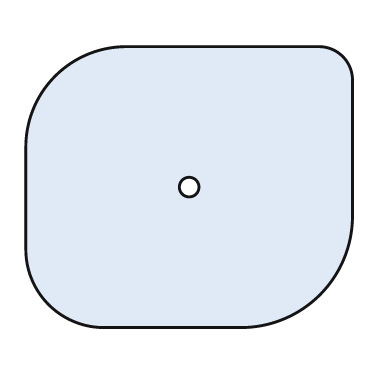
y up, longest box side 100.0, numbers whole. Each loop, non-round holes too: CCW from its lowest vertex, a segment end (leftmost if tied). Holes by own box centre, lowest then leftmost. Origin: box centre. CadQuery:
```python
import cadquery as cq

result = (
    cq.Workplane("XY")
    .moveTo(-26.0, -43.0)
    .lineTo(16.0, -43.0)
    .threePointArc((40.0, -33.0), (50.0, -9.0))
    .lineTo(50.0, 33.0)
    .threePointArc((47.0, 40.0), (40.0, 43.0))
    .lineTo(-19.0, 43.0)
    .threePointArc((-41.0, 34.0), (-50.0, 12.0))
    .lineTo(-50.0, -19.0)
    .threePointArc((-43.0, -36.0), (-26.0, -43.0))
    .close()
    .moveTo(0.0, 0.0)
    .circle(3.0)
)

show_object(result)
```